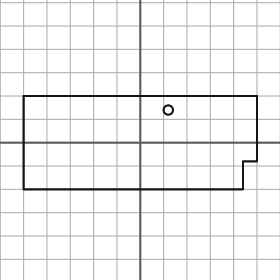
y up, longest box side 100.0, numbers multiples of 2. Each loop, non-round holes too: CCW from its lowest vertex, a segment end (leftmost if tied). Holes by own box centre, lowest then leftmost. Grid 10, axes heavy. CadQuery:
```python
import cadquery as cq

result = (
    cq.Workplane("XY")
    .moveTo(-50.0, -20.0)
    .lineTo(44.0, -20.0)
    .lineTo(44.0, -8.0)
    .lineTo(50.0, -8.0)
    .lineTo(50.0, 20.0)
    .lineTo(-50.0, 20.0)
    .close()
    .moveTo(12.0, 14.0)
    .circle(2.0)
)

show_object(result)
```